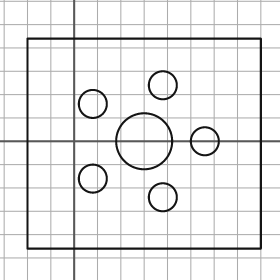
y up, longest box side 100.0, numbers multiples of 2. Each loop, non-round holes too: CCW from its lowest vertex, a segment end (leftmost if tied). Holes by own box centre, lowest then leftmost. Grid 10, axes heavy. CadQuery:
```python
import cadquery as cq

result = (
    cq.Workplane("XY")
    .moveTo(-20.0, -46.0)
    .lineTo(80.0, -46.0)
    .lineTo(80.0, 44.0)
    .lineTo(-20.0, 44.0)
    .close()
    .moveTo(38.0, -24.0)
    .circle(6.0)
    .moveTo(8.0, -16.0)
    .circle(6.0)
    .moveTo(30.0, 0.0)
    .circle(12.0)
    .moveTo(56.0, 0.0)
    .circle(6.0)
    .moveTo(8.0, 16.0)
    .circle(6.0)
    .moveTo(38.0, 24.0)
    .circle(6.0)
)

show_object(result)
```